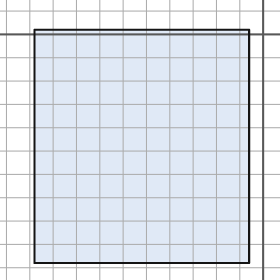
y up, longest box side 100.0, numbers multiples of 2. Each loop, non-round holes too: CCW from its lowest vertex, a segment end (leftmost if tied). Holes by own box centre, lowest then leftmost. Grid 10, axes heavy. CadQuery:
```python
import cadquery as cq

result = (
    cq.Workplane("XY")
    .moveTo(-98.0, -98.0)
    .lineTo(-6.0, -98.0)
    .lineTo(-6.0, 2.0)
    .lineTo(-98.0, 2.0)
    .close()
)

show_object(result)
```